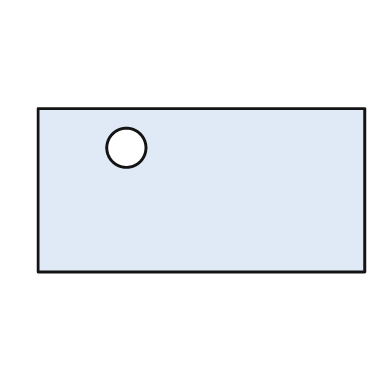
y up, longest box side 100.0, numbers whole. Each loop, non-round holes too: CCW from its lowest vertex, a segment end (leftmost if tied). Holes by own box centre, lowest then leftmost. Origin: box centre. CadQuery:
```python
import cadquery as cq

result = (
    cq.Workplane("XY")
    .moveTo(-50.0, -25.0)
    .lineTo(50.0, -25.0)
    .lineTo(50.0, 25.0)
    .lineTo(-50.0, 25.0)
    .close()
    .moveTo(-23.0, 13.0)
    .circle(6.0)
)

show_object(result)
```